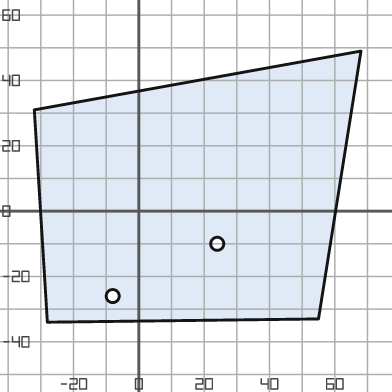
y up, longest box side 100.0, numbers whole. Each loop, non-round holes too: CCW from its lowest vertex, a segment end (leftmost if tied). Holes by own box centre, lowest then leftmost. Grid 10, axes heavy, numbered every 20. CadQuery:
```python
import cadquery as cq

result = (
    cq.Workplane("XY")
    .moveTo(-28.0, -34.0)
    .lineTo(55.0, -33.0)
    .lineTo(68.0, 49.0)
    .lineTo(-32.0, 31.0)
    .close()
    .moveTo(-8.0, -26.0)
    .circle(2.0)
    .moveTo(24.0, -10.0)
    .circle(2.0)
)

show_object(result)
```